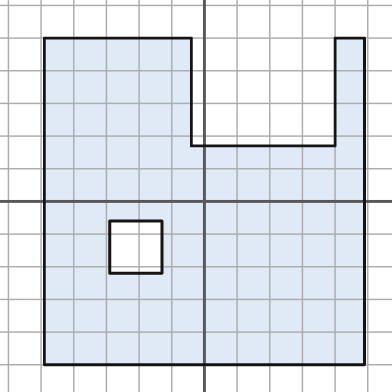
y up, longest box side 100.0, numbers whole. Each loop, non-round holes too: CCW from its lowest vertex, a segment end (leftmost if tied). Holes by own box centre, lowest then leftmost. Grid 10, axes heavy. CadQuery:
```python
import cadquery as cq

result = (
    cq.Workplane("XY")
    .moveTo(-49.0, -50.0)
    .lineTo(49.0, -50.0)
    .lineTo(49.0, 50.0)
    .lineTo(40.0, 50.0)
    .lineTo(40.0, 17.0)
    .lineTo(-4.0, 17.0)
    .lineTo(-4.0, 50.0)
    .lineTo(-49.0, 50.0)
    .close()
    .moveTo(-29.0, -22.0)
    .lineTo(-13.0, -22.0)
    .lineTo(-13.0, -6.0)
    .lineTo(-29.0, -6.0)
    .close()
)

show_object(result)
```